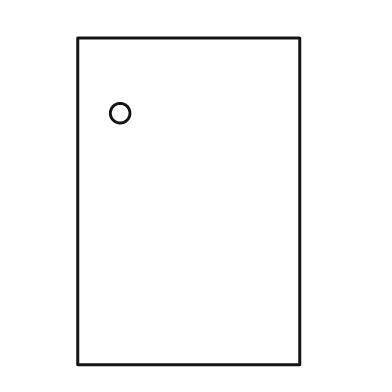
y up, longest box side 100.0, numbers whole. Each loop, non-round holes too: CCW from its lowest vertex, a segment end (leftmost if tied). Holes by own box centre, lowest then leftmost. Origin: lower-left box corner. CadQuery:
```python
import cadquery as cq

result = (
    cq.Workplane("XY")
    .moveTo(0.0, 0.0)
    .lineTo(68.0, 0.0)
    .lineTo(68.0, 100.0)
    .lineTo(0.0, 100.0)
    .close()
    .moveTo(13.0, 77.0)
    .circle(3.0)
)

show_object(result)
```